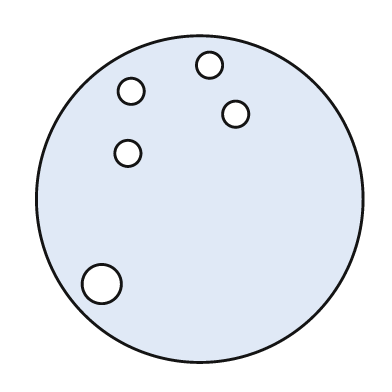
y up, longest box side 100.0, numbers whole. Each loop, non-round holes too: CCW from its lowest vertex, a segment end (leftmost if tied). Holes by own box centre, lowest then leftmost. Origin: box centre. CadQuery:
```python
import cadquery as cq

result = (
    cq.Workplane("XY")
    .moveTo(0.0, 0.0)
    .circle(50.0)
    .moveTo(-30.0, -26.0)
    .circle(6.0)
    .moveTo(-22.0, 14.0)
    .circle(4.0)
    .moveTo(11.0, 26.0)
    .circle(4.0)
    .moveTo(-21.0, 33.0)
    .circle(4.0)
    .moveTo(3.0, 41.0)
    .circle(4.0)
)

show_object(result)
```